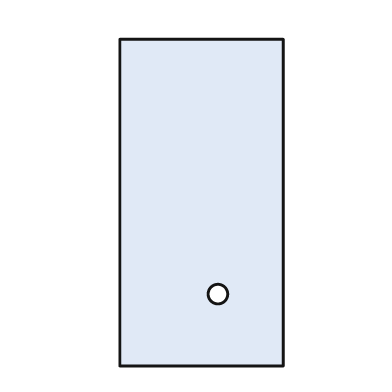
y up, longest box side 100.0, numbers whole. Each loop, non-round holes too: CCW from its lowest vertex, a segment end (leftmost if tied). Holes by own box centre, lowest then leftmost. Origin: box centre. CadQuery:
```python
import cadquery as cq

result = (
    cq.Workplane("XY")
    .moveTo(-25.0, -50.0)
    .lineTo(25.0, -50.0)
    .lineTo(25.0, 50.0)
    .lineTo(-25.0, 50.0)
    .close()
    .moveTo(5.0, -28.0)
    .circle(3.0)
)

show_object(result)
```